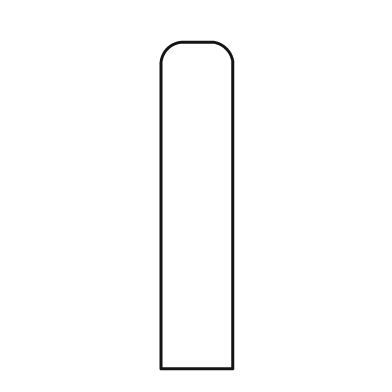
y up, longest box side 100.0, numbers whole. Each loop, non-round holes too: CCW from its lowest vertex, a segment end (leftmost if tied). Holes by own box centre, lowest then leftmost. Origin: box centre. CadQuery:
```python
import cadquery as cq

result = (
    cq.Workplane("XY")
    .moveTo(-11.0, -50.0)
    .lineTo(11.0, -50.0)
    .lineTo(11.0, 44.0)
    .threePointArc((9.0, 48.0), (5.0, 50.0))
    .lineTo(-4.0, 50.0)
    .threePointArc((-9.0, 48.0), (-11.0, 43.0))
    .close()
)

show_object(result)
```